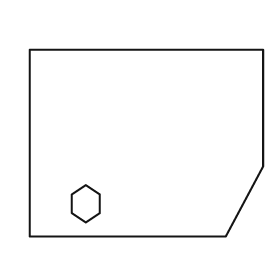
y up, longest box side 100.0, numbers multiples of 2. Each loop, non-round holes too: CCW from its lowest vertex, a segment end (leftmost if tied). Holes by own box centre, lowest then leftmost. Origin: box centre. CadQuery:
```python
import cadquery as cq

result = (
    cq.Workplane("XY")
    .moveTo(-50.0, -40.0)
    .lineTo(34.0, -40.0)
    .lineTo(50.0, -10.0)
    .lineTo(50.0, 40.0)
    .lineTo(-50.0, 40.0)
    .close()
    .moveTo(-26.0, -34.0)
    .lineTo(-20.0, -30.0)
    .lineTo(-20.0, -22.0)
    .lineTo(-26.0, -18.0)
    .lineTo(-32.0, -22.0)
    .lineTo(-32.0, -30.0)
    .close()
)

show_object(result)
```